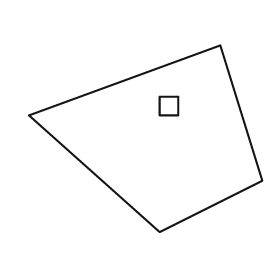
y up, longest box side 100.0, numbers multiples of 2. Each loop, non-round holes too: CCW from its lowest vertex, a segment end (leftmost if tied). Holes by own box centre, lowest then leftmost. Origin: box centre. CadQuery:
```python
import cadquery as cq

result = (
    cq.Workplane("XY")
    .moveTo(6.0, -40.0)
    .lineTo(50.0, -18.0)
    .lineTo(32.0, 40.0)
    .lineTo(-50.0, 10.0)
    .close()
    .moveTo(6.0, 10.0)
    .lineTo(14.0, 10.0)
    .lineTo(14.0, 18.0)
    .lineTo(6.0, 18.0)
    .close()
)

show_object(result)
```